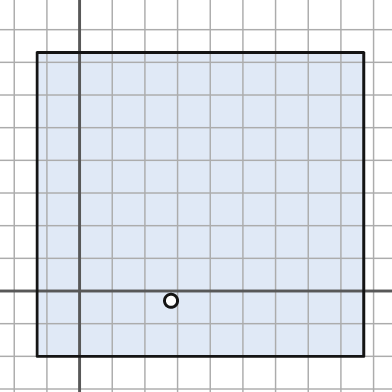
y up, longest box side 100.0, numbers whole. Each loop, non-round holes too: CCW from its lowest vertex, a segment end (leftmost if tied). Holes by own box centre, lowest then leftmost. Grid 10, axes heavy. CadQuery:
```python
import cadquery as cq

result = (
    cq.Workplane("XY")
    .moveTo(-13.0, -20.0)
    .lineTo(87.0, -20.0)
    .lineTo(87.0, 73.0)
    .lineTo(-13.0, 73.0)
    .close()
    .moveTo(28.0, -3.0)
    .circle(2.0)
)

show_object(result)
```